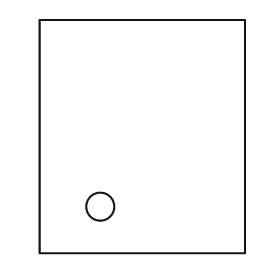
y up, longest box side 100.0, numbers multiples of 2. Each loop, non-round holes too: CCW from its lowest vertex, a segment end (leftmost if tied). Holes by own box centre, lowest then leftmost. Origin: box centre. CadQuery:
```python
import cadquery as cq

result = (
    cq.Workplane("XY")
    .moveTo(-44.0, -50.0)
    .lineTo(44.0, -50.0)
    .lineTo(44.0, 50.0)
    .lineTo(-44.0, 50.0)
    .close()
    .moveTo(-18.0, -30.0)
    .circle(6.0)
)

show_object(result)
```